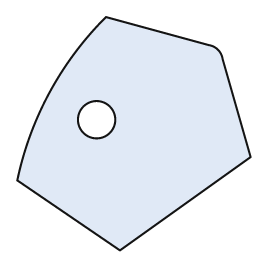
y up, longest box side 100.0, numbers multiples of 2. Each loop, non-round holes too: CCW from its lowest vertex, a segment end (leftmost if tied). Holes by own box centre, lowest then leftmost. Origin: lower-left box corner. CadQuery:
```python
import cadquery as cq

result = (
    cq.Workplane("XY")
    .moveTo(44.0, 0.0)
    .lineTo(100.0, 40.0)
    .lineTo(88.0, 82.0)
    .threePointArc((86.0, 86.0), (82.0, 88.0))
    .lineTo(38.0, 100.0)
    .threePointArc((14.0, 68.0), (0.0, 30.0))
    .close()
    .moveTo(34.0, 56.0)
    .circle(8.0)
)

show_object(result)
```